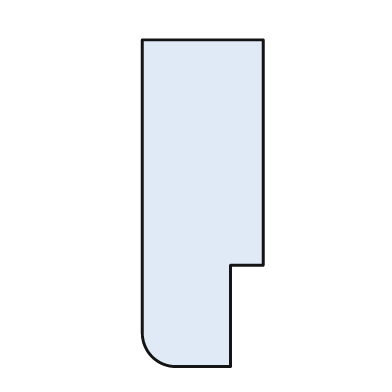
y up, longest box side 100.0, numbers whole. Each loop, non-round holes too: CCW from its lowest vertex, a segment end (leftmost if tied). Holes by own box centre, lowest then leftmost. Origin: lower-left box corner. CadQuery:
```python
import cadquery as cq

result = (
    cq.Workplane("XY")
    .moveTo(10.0, 0.0)
    .lineTo(27.0, 0.0)
    .lineTo(27.0, 31.0)
    .lineTo(37.0, 31.0)
    .lineTo(37.0, 100.0)
    .lineTo(0.0, 100.0)
    .lineTo(0.0, 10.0)
    .threePointArc((3.0, 3.0), (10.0, 0.0))
    .close()
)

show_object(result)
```